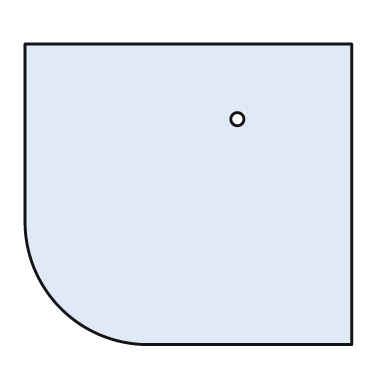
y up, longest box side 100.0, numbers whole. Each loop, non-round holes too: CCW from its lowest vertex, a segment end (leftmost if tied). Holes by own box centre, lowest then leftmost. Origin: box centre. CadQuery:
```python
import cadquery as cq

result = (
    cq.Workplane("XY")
    .moveTo(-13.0, -46.0)
    .lineTo(50.0, -46.0)
    .lineTo(50.0, 46.0)
    .lineTo(-50.0, 46.0)
    .lineTo(-50.0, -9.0)
    .threePointArc((-39.0, -35.0), (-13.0, -46.0))
    .close()
    .moveTo(15.0, 23.0)
    .circle(2.0)
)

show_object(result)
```